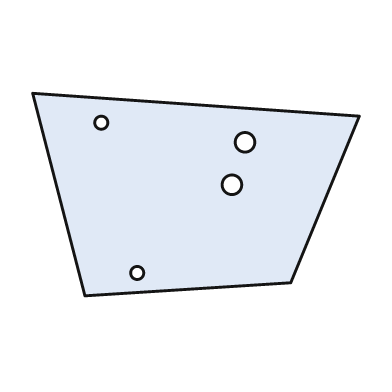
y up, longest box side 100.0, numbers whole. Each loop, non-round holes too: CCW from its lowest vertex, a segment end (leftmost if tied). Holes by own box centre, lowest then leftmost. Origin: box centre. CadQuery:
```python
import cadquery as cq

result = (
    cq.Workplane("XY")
    .moveTo(-34.0, -31.0)
    .lineTo(29.0, -27.0)
    .lineTo(50.0, 24.0)
    .lineTo(-50.0, 31.0)
    .close()
    .moveTo(-18.0, -24.0)
    .circle(2.0)
    .moveTo(11.0, 3.0)
    .circle(3.0)
    .moveTo(15.0, 16.0)
    .circle(3.0)
    .moveTo(-29.0, 22.0)
    .circle(2.0)
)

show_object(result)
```